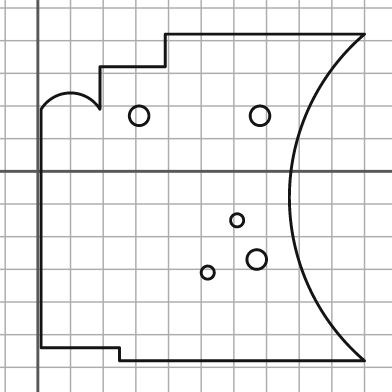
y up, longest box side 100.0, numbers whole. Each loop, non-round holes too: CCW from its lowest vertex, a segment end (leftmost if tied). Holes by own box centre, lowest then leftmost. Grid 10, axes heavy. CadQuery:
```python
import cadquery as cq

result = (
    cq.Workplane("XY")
    .moveTo(25.0, -58.0)
    .lineTo(100.0, -58.0)
    .threePointArc((77.0, -8.0), (100.0, 42.0))
    .lineTo(39.0, 42.0)
    .lineTo(39.0, 32.0)
    .lineTo(19.0, 32.0)
    .lineTo(19.0, 19.0)
    .threePointArc((10.0, 24.0), (1.0, 19.0))
    .lineTo(1.0, -54.0)
    .lineTo(25.0, -54.0)
    .close()
    .moveTo(52.0, -31.0)
    .circle(2.0)
    .moveTo(67.0, -27.0)
    .circle(3.0)
    .moveTo(61.0, -15.0)
    .circle(2.0)
    .moveTo(31.0, 17.0)
    .circle(3.0)
    .moveTo(68.0, 17.0)
    .circle(3.0)
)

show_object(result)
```